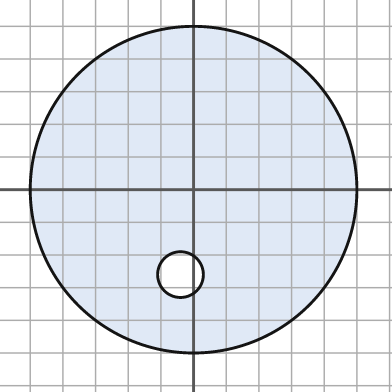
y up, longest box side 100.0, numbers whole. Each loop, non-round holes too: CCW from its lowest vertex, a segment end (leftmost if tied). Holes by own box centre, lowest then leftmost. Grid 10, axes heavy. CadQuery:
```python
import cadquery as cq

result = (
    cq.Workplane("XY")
    .moveTo(0.0, 0.0)
    .circle(50.0)
    .moveTo(-4.0, -26.0)
    .circle(7.0)
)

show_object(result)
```